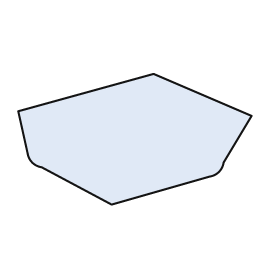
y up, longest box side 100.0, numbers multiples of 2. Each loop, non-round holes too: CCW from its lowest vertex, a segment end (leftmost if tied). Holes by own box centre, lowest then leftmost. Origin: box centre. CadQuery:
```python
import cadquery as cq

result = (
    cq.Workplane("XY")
    .moveTo(-10.0, -28.0)
    .lineTo(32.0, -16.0)
    .threePointArc((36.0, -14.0), (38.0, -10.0))
    .lineTo(50.0, 10.0)
    .lineTo(8.0, 28.0)
    .lineTo(-50.0, 12.0)
    .lineTo(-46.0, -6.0)
    .threePointArc((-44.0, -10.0), (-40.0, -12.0))
    .close()
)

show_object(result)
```